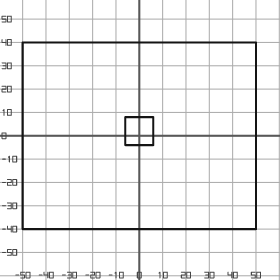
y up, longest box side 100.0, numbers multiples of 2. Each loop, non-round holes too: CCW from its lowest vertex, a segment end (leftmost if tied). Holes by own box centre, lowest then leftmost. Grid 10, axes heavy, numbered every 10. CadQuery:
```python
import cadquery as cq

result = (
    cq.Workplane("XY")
    .moveTo(-50.0, -40.0)
    .lineTo(50.0, -40.0)
    .lineTo(50.0, 40.0)
    .lineTo(-50.0, 40.0)
    .close()
    .moveTo(-6.0, -4.0)
    .lineTo(6.0, -4.0)
    .lineTo(6.0, 8.0)
    .lineTo(-6.0, 8.0)
    .close()
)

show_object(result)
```